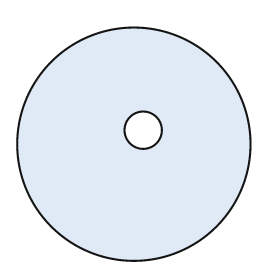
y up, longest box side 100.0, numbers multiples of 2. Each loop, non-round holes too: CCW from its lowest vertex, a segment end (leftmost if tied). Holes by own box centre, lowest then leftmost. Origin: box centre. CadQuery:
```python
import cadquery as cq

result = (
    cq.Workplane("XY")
    .moveTo(0.0, 0.0)
    .circle(50.0)
    .moveTo(4.0, 6.0)
    .circle(8.0)
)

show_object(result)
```